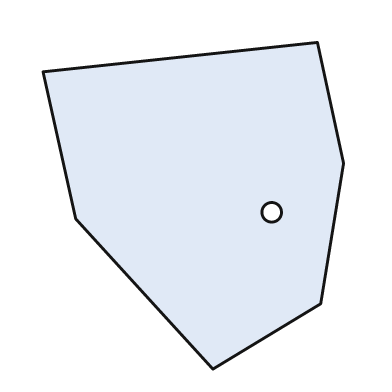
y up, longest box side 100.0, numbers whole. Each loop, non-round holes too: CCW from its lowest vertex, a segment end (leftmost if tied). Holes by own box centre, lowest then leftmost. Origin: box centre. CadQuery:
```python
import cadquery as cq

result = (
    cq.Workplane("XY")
    .moveTo(6.0, -50.0)
    .lineTo(39.0, -30.0)
    .lineTo(46.0, 13.0)
    .lineTo(38.0, 50.0)
    .lineTo(-46.0, 41.0)
    .lineTo(-36.0, -4.0)
    .close()
    .moveTo(24.0, -2.0)
    .circle(3.0)
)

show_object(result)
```